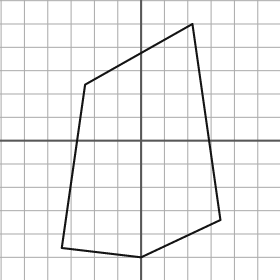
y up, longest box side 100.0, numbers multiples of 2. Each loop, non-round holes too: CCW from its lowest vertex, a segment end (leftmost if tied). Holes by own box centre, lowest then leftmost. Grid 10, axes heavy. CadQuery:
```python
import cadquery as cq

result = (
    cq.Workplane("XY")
    .moveTo(0.0, -50.0)
    .lineTo(34.0, -34.0)
    .lineTo(22.0, 50.0)
    .lineTo(-24.0, 24.0)
    .lineTo(-34.0, -46.0)
    .close()
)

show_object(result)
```